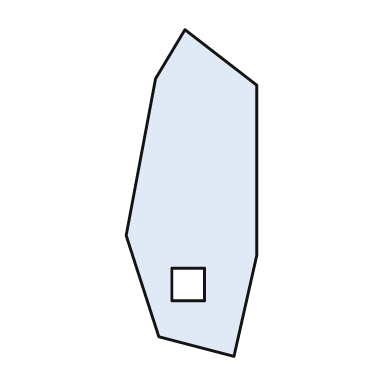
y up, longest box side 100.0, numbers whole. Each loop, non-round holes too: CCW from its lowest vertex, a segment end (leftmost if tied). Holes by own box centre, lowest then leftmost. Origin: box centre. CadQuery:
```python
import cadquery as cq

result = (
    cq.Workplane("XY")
    .moveTo(13.0, -50.0)
    .lineTo(20.0, -19.0)
    .lineTo(20.0, 33.0)
    .lineTo(-2.0, 50.0)
    .lineTo(-11.0, 35.0)
    .lineTo(-20.0, -13.0)
    .lineTo(-10.0, -44.0)
    .close()
    .moveTo(-6.0, -33.0)
    .lineTo(4.0, -33.0)
    .lineTo(4.0, -23.0)
    .lineTo(-6.0, -23.0)
    .close()
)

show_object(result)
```